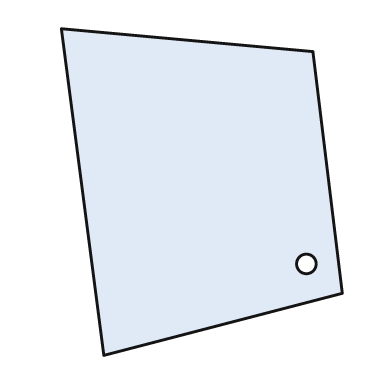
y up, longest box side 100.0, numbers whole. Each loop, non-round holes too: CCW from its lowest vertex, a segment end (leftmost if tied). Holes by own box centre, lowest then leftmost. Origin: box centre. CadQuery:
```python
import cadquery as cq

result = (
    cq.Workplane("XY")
    .moveTo(-30.0, -50.0)
    .lineTo(43.0, -31.0)
    .lineTo(34.0, 43.0)
    .lineTo(-43.0, 50.0)
    .close()
    .moveTo(32.0, -22.0)
    .circle(3.0)
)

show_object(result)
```